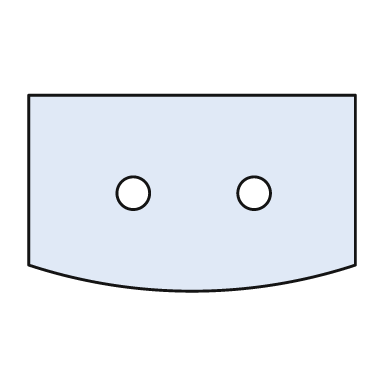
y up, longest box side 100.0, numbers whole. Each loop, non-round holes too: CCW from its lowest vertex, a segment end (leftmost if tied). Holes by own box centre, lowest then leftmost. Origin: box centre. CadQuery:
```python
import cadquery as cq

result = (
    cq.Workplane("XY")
    .moveTo(-50.0, -22.0)
    .threePointArc((0.0, -30.0), (50.0, -22.0))
    .lineTo(50.0, 30.0)
    .lineTo(-50.0, 30.0)
    .close()
    .moveTo(-18.0, 0.0)
    .circle(5.0)
    .moveTo(19.0, 0.0)
    .circle(5.0)
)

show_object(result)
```